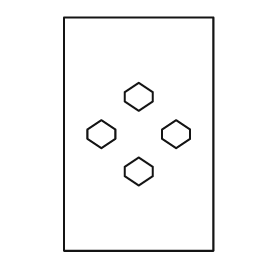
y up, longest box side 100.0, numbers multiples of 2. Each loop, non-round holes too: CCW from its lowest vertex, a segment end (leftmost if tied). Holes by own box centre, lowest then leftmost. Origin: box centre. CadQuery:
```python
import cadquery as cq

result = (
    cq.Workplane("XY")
    .moveTo(-32.0, -50.0)
    .lineTo(32.0, -50.0)
    .lineTo(32.0, 50.0)
    .lineTo(-32.0, 50.0)
    .close()
    .moveTo(0.0, -22.0)
    .lineTo(6.0, -18.0)
    .lineTo(6.0, -14.0)
    .lineTo(0.0, -10.0)
    .lineTo(-6.0, -14.0)
    .lineTo(-6.0, -18.0)
    .close()
    .moveTo(-16.0, -6.0)
    .lineTo(-10.0, -2.0)
    .lineTo(-10.0, 2.0)
    .lineTo(-16.0, 6.0)
    .lineTo(-22.0, 2.0)
    .lineTo(-22.0, -2.0)
    .close()
    .moveTo(16.0, -6.0)
    .lineTo(22.0, -2.0)
    .lineTo(22.0, 2.0)
    .lineTo(16.0, 6.0)
    .lineTo(10.0, 2.0)
    .lineTo(10.0, -2.0)
    .close()
    .moveTo(0.0, 10.0)
    .lineTo(6.0, 14.0)
    .lineTo(6.0, 18.0)
    .lineTo(0.0, 22.0)
    .lineTo(-6.0, 18.0)
    .lineTo(-6.0, 14.0)
    .close()
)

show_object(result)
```